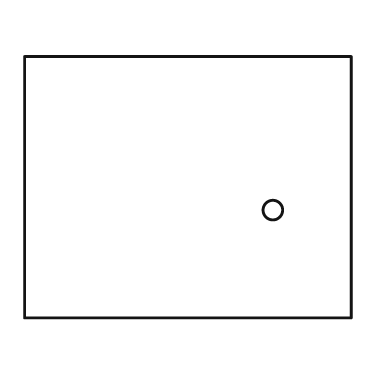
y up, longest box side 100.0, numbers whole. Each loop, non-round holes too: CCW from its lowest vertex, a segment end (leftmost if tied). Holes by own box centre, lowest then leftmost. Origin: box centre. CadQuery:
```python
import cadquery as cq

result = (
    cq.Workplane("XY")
    .moveTo(-50.0, -40.0)
    .lineTo(50.0, -40.0)
    .lineTo(50.0, 40.0)
    .lineTo(-50.0, 40.0)
    .close()
    .moveTo(26.0, -7.0)
    .circle(3.0)
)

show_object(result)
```